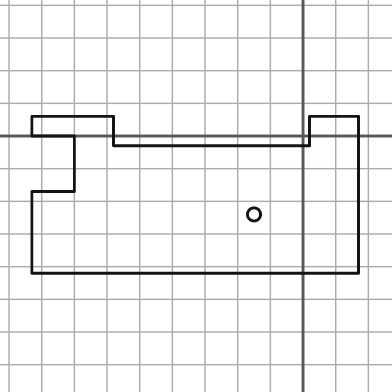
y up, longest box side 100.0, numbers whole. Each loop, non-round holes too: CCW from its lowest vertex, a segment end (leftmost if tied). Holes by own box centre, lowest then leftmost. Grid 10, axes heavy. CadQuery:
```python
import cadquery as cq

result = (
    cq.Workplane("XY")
    .moveTo(-83.0, -42.0)
    .lineTo(17.0, -42.0)
    .lineTo(17.0, 6.0)
    .lineTo(2.0, 6.0)
    .lineTo(2.0, -3.0)
    .lineTo(-58.0, -3.0)
    .lineTo(-58.0, 6.0)
    .lineTo(-83.0, 6.0)
    .lineTo(-83.0, 0.0)
    .lineTo(-70.0, 0.0)
    .lineTo(-70.0, -17.0)
    .lineTo(-83.0, -17.0)
    .close()
    .moveTo(-15.0, -24.0)
    .circle(2.0)
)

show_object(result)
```